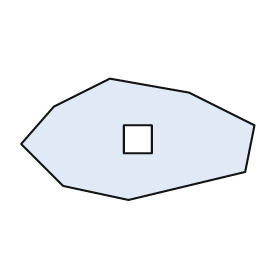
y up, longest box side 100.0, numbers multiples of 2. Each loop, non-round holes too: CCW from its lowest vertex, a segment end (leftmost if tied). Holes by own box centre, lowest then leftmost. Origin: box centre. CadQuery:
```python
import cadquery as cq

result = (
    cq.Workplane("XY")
    .moveTo(-4.0, -26.0)
    .lineTo(46.0, -14.0)
    .lineTo(50.0, 6.0)
    .lineTo(22.0, 20.0)
    .lineTo(-12.0, 26.0)
    .lineTo(-36.0, 14.0)
    .lineTo(-50.0, -2.0)
    .lineTo(-32.0, -20.0)
    .close()
    .moveTo(-6.0, -6.0)
    .lineTo(6.0, -6.0)
    .lineTo(6.0, 6.0)
    .lineTo(-6.0, 6.0)
    .close()
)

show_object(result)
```